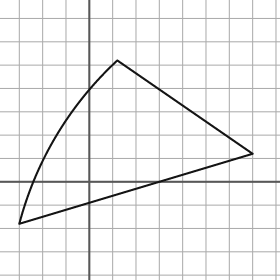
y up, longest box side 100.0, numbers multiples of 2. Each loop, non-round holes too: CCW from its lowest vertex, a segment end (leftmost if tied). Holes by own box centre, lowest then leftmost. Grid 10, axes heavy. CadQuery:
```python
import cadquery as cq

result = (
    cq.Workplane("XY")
    .moveTo(-30.0, -18.0)
    .lineTo(70.0, 12.0)
    .lineTo(12.0, 52.0)
    .threePointArc((-14.0, 20.0), (-30.0, -18.0))
    .close()
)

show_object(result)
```